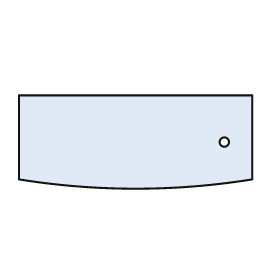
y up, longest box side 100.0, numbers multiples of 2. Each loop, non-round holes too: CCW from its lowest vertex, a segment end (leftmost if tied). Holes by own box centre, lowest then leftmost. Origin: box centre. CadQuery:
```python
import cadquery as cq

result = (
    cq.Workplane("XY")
    .moveTo(-50.0, -16.0)
    .threePointArc((0.0, -20.0), (50.0, -16.0))
    .lineTo(50.0, 20.0)
    .lineTo(-50.0, 20.0)
    .close()
    .moveTo(38.0, 0.0)
    .circle(2.0)
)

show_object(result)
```